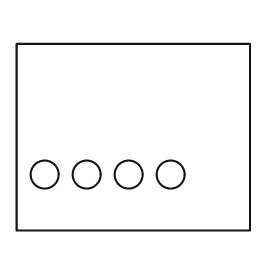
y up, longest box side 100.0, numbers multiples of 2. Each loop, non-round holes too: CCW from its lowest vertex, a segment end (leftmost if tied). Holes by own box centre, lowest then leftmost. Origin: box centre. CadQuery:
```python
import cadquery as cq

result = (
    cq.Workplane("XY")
    .moveTo(-50.0, -40.0)
    .lineTo(50.0, -40.0)
    .lineTo(50.0, 40.0)
    .lineTo(-50.0, 40.0)
    .close()
    .moveTo(-38.0, -16.0)
    .circle(6.0)
    .moveTo(-20.0, -16.0)
    .circle(6.0)
    .moveTo(-2.0, -16.0)
    .circle(6.0)
    .moveTo(16.0, -16.0)
    .circle(6.0)
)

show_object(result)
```